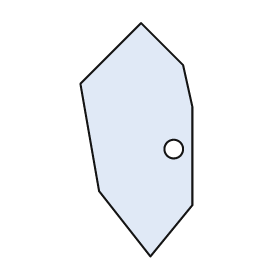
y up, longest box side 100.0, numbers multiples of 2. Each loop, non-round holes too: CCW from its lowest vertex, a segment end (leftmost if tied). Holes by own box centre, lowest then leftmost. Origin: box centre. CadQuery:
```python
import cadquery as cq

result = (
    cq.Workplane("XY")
    .moveTo(6.0, -50.0)
    .lineTo(24.0, -28.0)
    .lineTo(24.0, 14.0)
    .lineTo(20.0, 32.0)
    .lineTo(2.0, 50.0)
    .lineTo(-24.0, 24.0)
    .lineTo(-16.0, -22.0)
    .close()
    .moveTo(16.0, -4.0)
    .circle(4.0)
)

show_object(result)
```